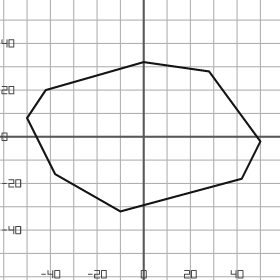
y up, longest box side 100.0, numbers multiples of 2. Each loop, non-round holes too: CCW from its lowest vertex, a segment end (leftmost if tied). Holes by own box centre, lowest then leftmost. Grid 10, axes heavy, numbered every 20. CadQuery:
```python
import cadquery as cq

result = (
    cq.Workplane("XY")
    .moveTo(-10.0, -32.0)
    .lineTo(42.0, -18.0)
    .lineTo(50.0, -2.0)
    .lineTo(28.0, 28.0)
    .lineTo(0.0, 32.0)
    .lineTo(-42.0, 20.0)
    .lineTo(-50.0, 8.0)
    .lineTo(-38.0, -16.0)
    .close()
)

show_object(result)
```